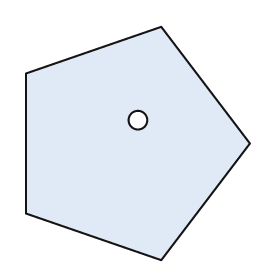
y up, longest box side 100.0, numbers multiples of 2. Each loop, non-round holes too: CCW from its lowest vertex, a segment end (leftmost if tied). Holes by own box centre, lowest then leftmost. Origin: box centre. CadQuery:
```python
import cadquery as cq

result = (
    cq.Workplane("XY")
    .moveTo(10.0, -50.0)
    .lineTo(48.0, 0.0)
    .lineTo(10.0, 50.0)
    .lineTo(-48.0, 30.0)
    .lineTo(-48.0, -30.0)
    .close()
    .moveTo(0.0, 10.0)
    .circle(4.0)
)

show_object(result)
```